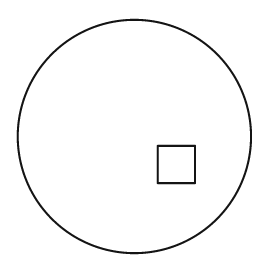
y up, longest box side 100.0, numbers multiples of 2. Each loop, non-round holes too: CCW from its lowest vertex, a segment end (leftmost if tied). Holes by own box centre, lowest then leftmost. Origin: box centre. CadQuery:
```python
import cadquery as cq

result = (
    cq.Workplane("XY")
    .moveTo(0.0, 0.0)
    .circle(50.0)
    .moveTo(10.0, -20.0)
    .lineTo(26.0, -20.0)
    .lineTo(26.0, -4.0)
    .lineTo(10.0, -4.0)
    .close()
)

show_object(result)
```